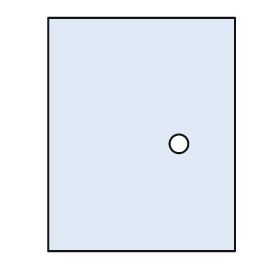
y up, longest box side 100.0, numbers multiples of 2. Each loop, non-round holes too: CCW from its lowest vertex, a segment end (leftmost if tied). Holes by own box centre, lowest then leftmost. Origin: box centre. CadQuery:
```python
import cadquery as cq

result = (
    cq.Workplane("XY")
    .moveTo(-40.0, -50.0)
    .lineTo(40.0, -50.0)
    .lineTo(40.0, 50.0)
    .lineTo(-40.0, 50.0)
    .close()
    .moveTo(16.0, -4.0)
    .circle(4.0)
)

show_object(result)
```